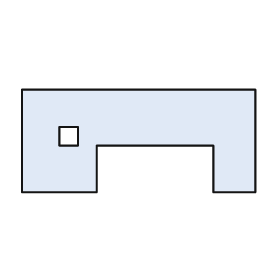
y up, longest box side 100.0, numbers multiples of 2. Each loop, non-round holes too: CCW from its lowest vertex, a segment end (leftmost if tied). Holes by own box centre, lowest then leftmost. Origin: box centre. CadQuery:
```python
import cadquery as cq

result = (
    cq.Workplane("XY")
    .moveTo(-50.0, -22.0)
    .lineTo(-18.0, -22.0)
    .lineTo(-18.0, -2.0)
    .lineTo(32.0, -2.0)
    .lineTo(32.0, -22.0)
    .lineTo(50.0, -22.0)
    .lineTo(50.0, 22.0)
    .lineTo(-50.0, 22.0)
    .close()
    .moveTo(-34.0, -2.0)
    .lineTo(-26.0, -2.0)
    .lineTo(-26.0, 6.0)
    .lineTo(-34.0, 6.0)
    .close()
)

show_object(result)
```